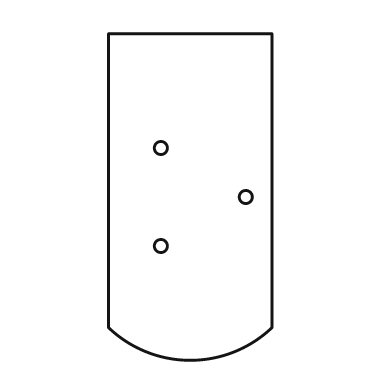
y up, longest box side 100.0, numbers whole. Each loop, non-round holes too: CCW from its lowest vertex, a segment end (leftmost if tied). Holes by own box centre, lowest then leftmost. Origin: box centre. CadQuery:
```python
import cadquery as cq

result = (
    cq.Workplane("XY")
    .moveTo(-25.0, -40.0)
    .threePointArc((0.0, -50.0), (25.0, -40.0))
    .lineTo(25.0, 50.0)
    .lineTo(-25.0, 50.0)
    .close()
    .moveTo(-9.0, -15.0)
    .circle(2.0)
    .moveTo(17.0, 0.0)
    .circle(2.0)
    .moveTo(-9.0, 15.0)
    .circle(2.0)
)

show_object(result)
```